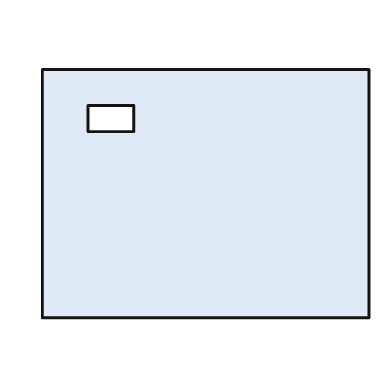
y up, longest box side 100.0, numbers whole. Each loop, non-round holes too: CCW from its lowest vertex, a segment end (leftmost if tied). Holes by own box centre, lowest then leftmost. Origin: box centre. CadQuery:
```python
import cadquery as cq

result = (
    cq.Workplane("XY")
    .moveTo(-50.0, -38.0)
    .lineTo(50.0, -38.0)
    .lineTo(50.0, 38.0)
    .lineTo(-50.0, 38.0)
    .close()
    .moveTo(-36.0, 19.0)
    .lineTo(-22.0, 19.0)
    .lineTo(-22.0, 27.0)
    .lineTo(-36.0, 27.0)
    .close()
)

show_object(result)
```